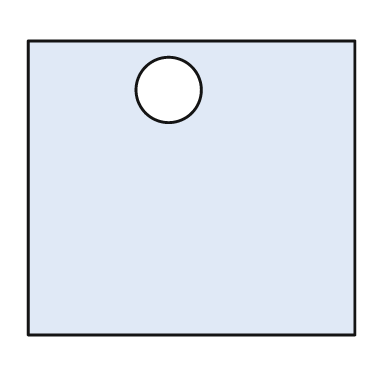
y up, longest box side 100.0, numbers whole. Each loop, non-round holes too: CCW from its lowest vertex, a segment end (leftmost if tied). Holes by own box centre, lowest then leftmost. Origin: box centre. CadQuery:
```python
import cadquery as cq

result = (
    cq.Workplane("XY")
    .moveTo(-50.0, -45.0)
    .lineTo(50.0, -45.0)
    .lineTo(50.0, 45.0)
    .lineTo(-50.0, 45.0)
    .close()
    .moveTo(-7.0, 30.0)
    .circle(10.0)
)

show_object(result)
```